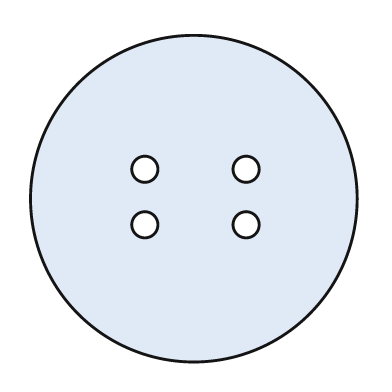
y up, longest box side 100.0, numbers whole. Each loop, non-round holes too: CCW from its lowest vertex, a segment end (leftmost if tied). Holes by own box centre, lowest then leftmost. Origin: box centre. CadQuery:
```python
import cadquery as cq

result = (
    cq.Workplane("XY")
    .moveTo(0.0, 0.0)
    .circle(50.0)
    .moveTo(-15.0, -8.0)
    .circle(4.0)
    .moveTo(16.0, -8.0)
    .circle(4.0)
    .moveTo(-15.0, 9.0)
    .circle(4.0)
    .moveTo(16.0, 9.0)
    .circle(4.0)
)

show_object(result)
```